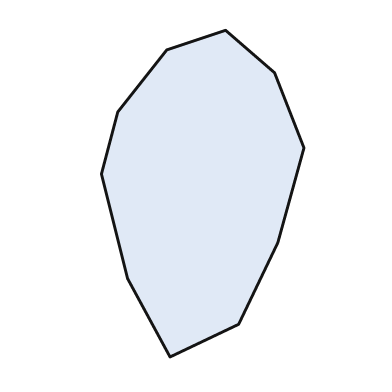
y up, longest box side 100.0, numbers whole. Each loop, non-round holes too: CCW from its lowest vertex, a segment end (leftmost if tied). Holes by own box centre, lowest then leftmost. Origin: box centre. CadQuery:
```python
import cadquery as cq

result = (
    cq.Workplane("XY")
    .moveTo(-10.0, -50.0)
    .lineTo(11.0, -40.0)
    .lineTo(23.0, -15.0)
    .lineTo(31.0, 14.0)
    .lineTo(22.0, 37.0)
    .lineTo(7.0, 50.0)
    .lineTo(-11.0, 44.0)
    .lineTo(-26.0, 25.0)
    .lineTo(-31.0, 6.0)
    .lineTo(-23.0, -26.0)
    .close()
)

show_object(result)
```